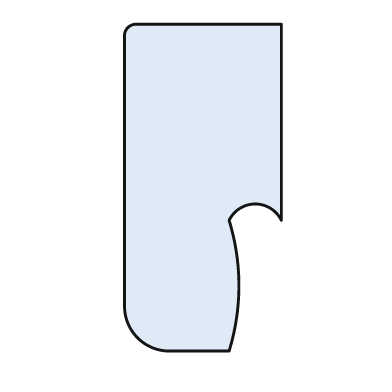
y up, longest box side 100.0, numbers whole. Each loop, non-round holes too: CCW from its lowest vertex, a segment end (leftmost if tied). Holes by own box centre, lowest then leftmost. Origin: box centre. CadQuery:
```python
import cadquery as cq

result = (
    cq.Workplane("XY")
    .moveTo(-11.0, -50.0)
    .lineTo(8.0, -50.0)
    .threePointArc((11.0, -30.0), (8.0, -10.0))
    .threePointArc((16.0, -5.0), (24.0, -10.0))
    .lineTo(24.0, 50.0)
    .lineTo(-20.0, 50.0)
    .threePointArc((-23.0, 49.0), (-24.0, 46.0))
    .lineTo(-24.0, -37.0)
    .threePointArc((-20.0, -46.0), (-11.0, -50.0))
    .close()
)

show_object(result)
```